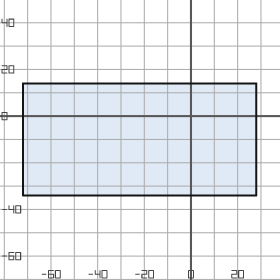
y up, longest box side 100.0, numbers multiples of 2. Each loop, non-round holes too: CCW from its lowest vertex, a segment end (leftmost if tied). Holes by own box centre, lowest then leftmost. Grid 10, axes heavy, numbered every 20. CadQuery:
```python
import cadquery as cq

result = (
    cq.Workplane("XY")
    .moveTo(-72.0, -34.0)
    .lineTo(28.0, -34.0)
    .lineTo(28.0, 14.0)
    .lineTo(-72.0, 14.0)
    .close()
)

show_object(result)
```